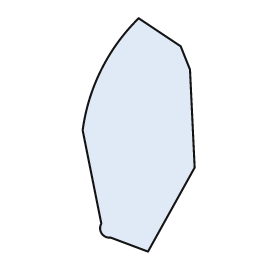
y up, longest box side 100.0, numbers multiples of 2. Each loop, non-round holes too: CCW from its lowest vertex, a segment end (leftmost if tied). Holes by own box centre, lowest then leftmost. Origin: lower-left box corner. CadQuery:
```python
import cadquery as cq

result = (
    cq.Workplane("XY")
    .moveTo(28.0, 0.0)
    .lineTo(48.0, 36.0)
    .lineTo(46.0, 78.0)
    .lineTo(42.0, 88.0)
    .lineTo(24.0, 100.0)
    .threePointArc((8.0, 78.0), (0.0, 52.0))
    .lineTo(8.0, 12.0)
    .threePointArc((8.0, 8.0), (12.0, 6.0))
    .close()
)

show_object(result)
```